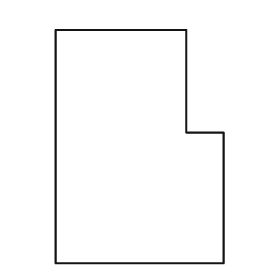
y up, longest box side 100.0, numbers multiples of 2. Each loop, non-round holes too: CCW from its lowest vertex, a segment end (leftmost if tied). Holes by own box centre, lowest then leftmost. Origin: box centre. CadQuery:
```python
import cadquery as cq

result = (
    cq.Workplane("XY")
    .moveTo(-36.0, -50.0)
    .lineTo(36.0, -50.0)
    .lineTo(36.0, 6.0)
    .lineTo(20.0, 6.0)
    .lineTo(20.0, 50.0)
    .lineTo(-36.0, 50.0)
    .close()
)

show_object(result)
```